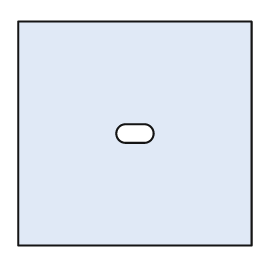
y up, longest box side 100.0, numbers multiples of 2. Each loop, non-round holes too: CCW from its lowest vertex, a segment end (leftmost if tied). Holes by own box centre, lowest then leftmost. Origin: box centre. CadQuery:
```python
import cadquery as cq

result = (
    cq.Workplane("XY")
    .moveTo(-50.0, -48.0)
    .lineTo(50.0, -48.0)
    .lineTo(50.0, 48.0)
    .lineTo(-50.0, 48.0)
    .close()
    .moveTo(-4.0, -4.0)
    .lineTo(4.0, -4.0)
    .threePointArc((8.0, 0.0), (4.0, 4.0))
    .lineTo(-4.0, 4.0)
    .threePointArc((-8.0, 0.0), (-4.0, -4.0))
    .close()
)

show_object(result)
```